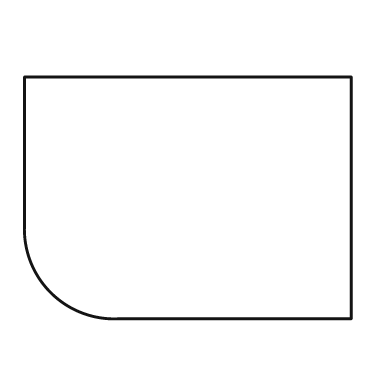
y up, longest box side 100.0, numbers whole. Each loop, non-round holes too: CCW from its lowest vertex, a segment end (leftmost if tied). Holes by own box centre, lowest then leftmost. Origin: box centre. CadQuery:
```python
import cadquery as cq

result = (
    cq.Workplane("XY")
    .moveTo(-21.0, -37.0)
    .lineTo(50.0, -37.0)
    .lineTo(50.0, 37.0)
    .lineTo(-50.0, 37.0)
    .lineTo(-50.0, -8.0)
    .threePointArc((-42.0, -29.0), (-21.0, -37.0))
    .close()
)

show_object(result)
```